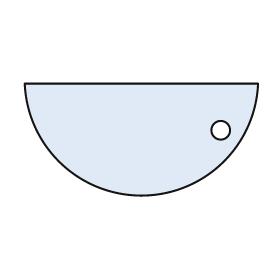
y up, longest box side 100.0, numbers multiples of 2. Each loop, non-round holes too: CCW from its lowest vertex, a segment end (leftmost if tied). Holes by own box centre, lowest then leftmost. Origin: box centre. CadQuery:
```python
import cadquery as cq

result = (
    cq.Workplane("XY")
    .moveTo(-50.0, 24.0)
    .threePointArc((0.0, -24.0), (50.0, 24.0))
    .close()
    .moveTo(34.0, 4.0)
    .circle(4.0)
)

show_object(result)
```